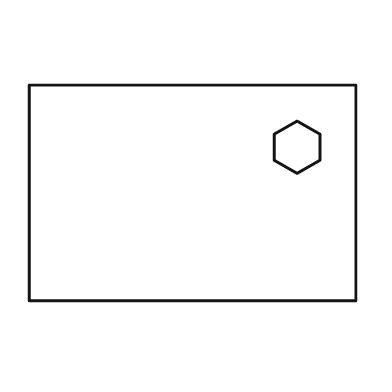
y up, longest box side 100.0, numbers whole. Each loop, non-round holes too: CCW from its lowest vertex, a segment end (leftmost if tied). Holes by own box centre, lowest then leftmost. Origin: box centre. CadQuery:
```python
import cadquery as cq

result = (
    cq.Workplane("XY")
    .moveTo(-50.0, -33.0)
    .lineTo(50.0, -33.0)
    .lineTo(50.0, 33.0)
    .lineTo(-50.0, 33.0)
    .close()
    .moveTo(32.0, 6.0)
    .lineTo(39.0, 10.0)
    .lineTo(39.0, 18.0)
    .lineTo(32.0, 22.0)
    .lineTo(25.0, 18.0)
    .lineTo(25.0, 10.0)
    .close()
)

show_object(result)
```